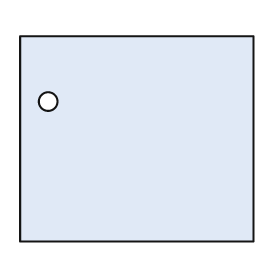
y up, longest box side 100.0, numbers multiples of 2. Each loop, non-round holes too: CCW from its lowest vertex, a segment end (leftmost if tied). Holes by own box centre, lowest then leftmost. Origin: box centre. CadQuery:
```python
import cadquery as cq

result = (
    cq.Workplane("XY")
    .moveTo(-50.0, -44.0)
    .lineTo(50.0, -44.0)
    .lineTo(50.0, 44.0)
    .lineTo(-50.0, 44.0)
    .close()
    .moveTo(-38.0, 16.0)
    .circle(4.0)
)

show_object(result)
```